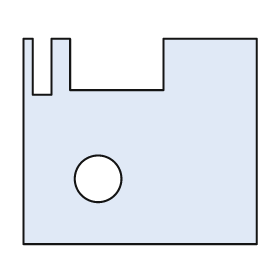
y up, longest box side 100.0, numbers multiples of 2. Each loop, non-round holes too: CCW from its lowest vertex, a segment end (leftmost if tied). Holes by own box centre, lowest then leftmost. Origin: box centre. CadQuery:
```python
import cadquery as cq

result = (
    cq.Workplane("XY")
    .moveTo(-50.0, -44.0)
    .lineTo(50.0, -44.0)
    .lineTo(50.0, 44.0)
    .lineTo(10.0, 44.0)
    .lineTo(10.0, 22.0)
    .lineTo(-30.0, 22.0)
    .lineTo(-30.0, 44.0)
    .lineTo(-38.0, 44.0)
    .lineTo(-38.0, 20.0)
    .lineTo(-46.0, 20.0)
    .lineTo(-46.0, 44.0)
    .lineTo(-50.0, 44.0)
    .close()
    .moveTo(-18.0, -16.0)
    .circle(10.0)
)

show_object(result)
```